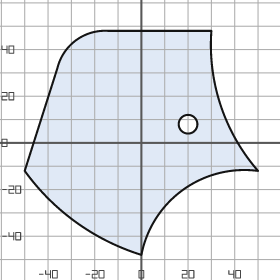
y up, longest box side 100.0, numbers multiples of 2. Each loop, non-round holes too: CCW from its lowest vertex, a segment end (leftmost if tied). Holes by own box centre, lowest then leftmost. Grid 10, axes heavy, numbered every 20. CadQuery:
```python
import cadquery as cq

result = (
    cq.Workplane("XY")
    .moveTo(0.0, -48.0)
    .threePointArc((18.0, -20.0), (50.0, -12.0))
    .threePointArc((34.0, 16.0), (30.0, 48.0))
    .lineTo(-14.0, 48.0)
    .threePointArc((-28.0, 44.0), (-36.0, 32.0))
    .lineTo(-50.0, -12.0)
    .threePointArc((-28.0, -34.0), (0.0, -48.0))
    .close()
    .moveTo(20.0, 8.0)
    .circle(4.0)
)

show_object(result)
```